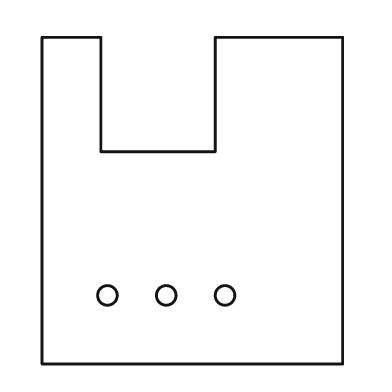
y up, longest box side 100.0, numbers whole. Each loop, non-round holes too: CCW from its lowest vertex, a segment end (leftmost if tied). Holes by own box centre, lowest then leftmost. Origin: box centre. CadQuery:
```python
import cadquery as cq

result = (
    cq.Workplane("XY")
    .moveTo(-46.0, -50.0)
    .lineTo(46.0, -50.0)
    .lineTo(46.0, 50.0)
    .lineTo(7.0, 50.0)
    .lineTo(7.0, 15.0)
    .lineTo(-28.0, 15.0)
    .lineTo(-28.0, 50.0)
    .lineTo(-46.0, 50.0)
    .close()
    .moveTo(-26.0, -29.0)
    .circle(3.0)
    .moveTo(-8.0, -29.0)
    .circle(3.0)
    .moveTo(10.0, -29.0)
    .circle(3.0)
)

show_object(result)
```